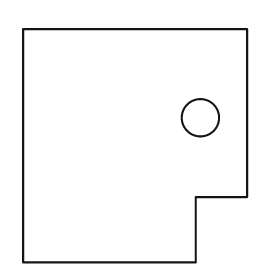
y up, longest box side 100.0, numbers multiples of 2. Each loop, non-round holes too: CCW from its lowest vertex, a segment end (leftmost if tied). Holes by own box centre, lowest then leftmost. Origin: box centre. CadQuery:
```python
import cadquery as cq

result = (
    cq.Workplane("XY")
    .moveTo(-48.0, -50.0)
    .lineTo(26.0, -50.0)
    .lineTo(26.0, -22.0)
    .lineTo(48.0, -22.0)
    .lineTo(48.0, 50.0)
    .lineTo(-48.0, 50.0)
    .close()
    .moveTo(28.0, 12.0)
    .circle(8.0)
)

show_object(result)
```